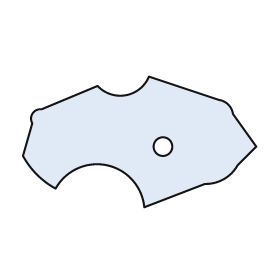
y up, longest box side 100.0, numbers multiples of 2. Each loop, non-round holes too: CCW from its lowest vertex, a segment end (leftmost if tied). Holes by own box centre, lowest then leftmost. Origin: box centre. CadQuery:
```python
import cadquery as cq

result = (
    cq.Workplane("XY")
    .moveTo(2.0, -28.0)
    .lineTo(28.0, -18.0)
    .threePointArc((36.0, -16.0), (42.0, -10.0))
    .lineTo(50.0, -2.0)
    .lineTo(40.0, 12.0)
    .threePointArc((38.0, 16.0), (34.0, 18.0))
    .lineTo(4.0, 28.0)
    .threePointArc((-6.0, 20.0), (-18.0, 24.0))
    .lineTo(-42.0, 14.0)
    .threePointArc((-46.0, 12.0), (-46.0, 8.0))
    .lineTo(-50.0, -6.0)
    .threePointArc((-44.0, -14.0), (-36.0, -20.0))
    .threePointArc((-14.0, -10.0), (2.0, -28.0))
    .close()
    .moveTo(10.0, -2.0)
    .circle(4.0)
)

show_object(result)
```